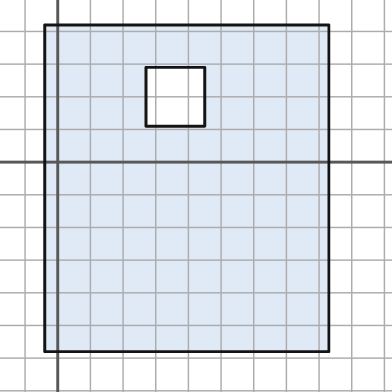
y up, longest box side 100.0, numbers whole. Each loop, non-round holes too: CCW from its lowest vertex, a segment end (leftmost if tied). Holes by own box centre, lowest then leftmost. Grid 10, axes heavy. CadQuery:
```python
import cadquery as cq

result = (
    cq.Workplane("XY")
    .moveTo(-4.0, -58.0)
    .lineTo(83.0, -58.0)
    .lineTo(83.0, 42.0)
    .lineTo(-4.0, 42.0)
    .close()
    .moveTo(27.0, 11.0)
    .lineTo(45.0, 11.0)
    .lineTo(45.0, 29.0)
    .lineTo(27.0, 29.0)
    .close()
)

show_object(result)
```